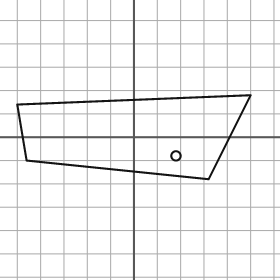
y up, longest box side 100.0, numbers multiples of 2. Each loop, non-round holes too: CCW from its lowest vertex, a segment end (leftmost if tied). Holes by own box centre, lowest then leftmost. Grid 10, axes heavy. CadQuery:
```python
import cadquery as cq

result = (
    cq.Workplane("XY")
    .moveTo(32.0, -18.0)
    .lineTo(50.0, 18.0)
    .lineTo(-50.0, 14.0)
    .lineTo(-46.0, -10.0)
    .close()
    .moveTo(18.0, -8.0)
    .circle(2.0)
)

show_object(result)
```